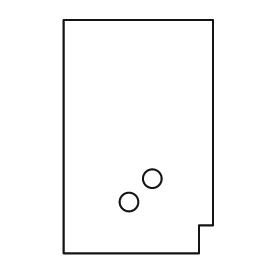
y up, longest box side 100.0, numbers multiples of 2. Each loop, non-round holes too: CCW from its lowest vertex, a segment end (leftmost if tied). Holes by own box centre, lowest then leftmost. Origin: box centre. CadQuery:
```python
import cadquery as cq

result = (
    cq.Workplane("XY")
    .moveTo(-32.0, -50.0)
    .lineTo(26.0, -50.0)
    .lineTo(26.0, -38.0)
    .lineTo(32.0, -38.0)
    .lineTo(32.0, 50.0)
    .lineTo(-32.0, 50.0)
    .close()
    .moveTo(-4.0, -28.0)
    .circle(4.0)
    .moveTo(6.0, -18.0)
    .circle(4.0)
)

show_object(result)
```